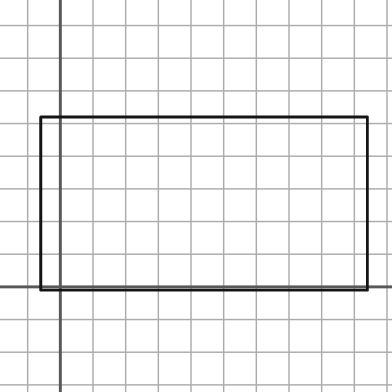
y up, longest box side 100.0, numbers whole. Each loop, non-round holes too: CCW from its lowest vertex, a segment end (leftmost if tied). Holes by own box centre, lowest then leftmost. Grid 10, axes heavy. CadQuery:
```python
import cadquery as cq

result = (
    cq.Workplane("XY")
    .moveTo(-6.0, -1.0)
    .lineTo(94.0, -1.0)
    .lineTo(94.0, 52.0)
    .lineTo(-6.0, 52.0)
    .close()
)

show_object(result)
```